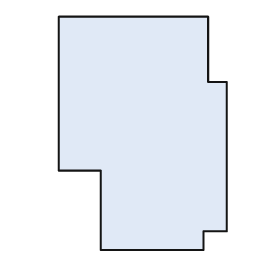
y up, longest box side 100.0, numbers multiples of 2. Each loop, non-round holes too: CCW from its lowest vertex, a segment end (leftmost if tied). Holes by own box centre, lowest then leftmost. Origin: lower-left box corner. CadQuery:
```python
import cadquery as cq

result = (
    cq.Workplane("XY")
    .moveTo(18.0, 0.0)
    .lineTo(62.0, 0.0)
    .lineTo(62.0, 8.0)
    .lineTo(72.0, 8.0)
    .lineTo(72.0, 72.0)
    .lineTo(64.0, 72.0)
    .lineTo(64.0, 100.0)
    .lineTo(0.0, 100.0)
    .lineTo(0.0, 34.0)
    .lineTo(18.0, 34.0)
    .close()
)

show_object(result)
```